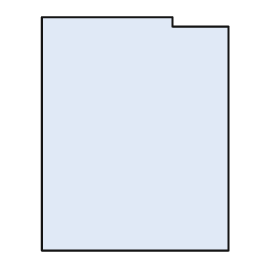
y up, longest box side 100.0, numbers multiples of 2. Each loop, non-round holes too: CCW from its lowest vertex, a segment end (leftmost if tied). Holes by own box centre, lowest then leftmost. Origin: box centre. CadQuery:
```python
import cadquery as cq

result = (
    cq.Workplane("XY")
    .moveTo(-40.0, -50.0)
    .lineTo(40.0, -50.0)
    .lineTo(40.0, 46.0)
    .lineTo(16.0, 46.0)
    .lineTo(16.0, 50.0)
    .lineTo(-40.0, 50.0)
    .close()
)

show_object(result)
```